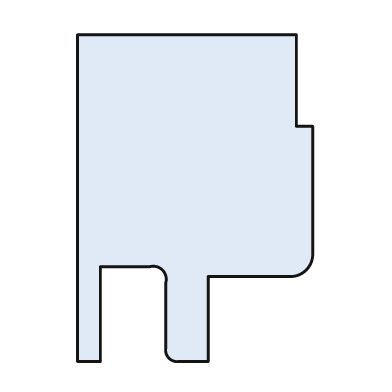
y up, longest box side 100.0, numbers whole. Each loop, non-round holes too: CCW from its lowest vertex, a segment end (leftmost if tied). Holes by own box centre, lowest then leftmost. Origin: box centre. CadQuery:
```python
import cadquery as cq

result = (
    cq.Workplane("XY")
    .moveTo(-36.0, -50.0)
    .lineTo(-29.0, -50.0)
    .lineTo(-29.0, -21.0)
    .lineTo(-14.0, -21.0)
    .threePointArc((-10.0, -22.0), (-9.0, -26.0))
    .lineTo(-9.0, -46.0)
    .threePointArc((-8.0, -49.0), (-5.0, -50.0))
    .lineTo(4.0, -50.0)
    .lineTo(4.0, -24.0)
    .lineTo(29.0, -24.0)
    .threePointArc((34.0, -22.0), (36.0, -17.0))
    .lineTo(36.0, 22.0)
    .lineTo(31.0, 22.0)
    .lineTo(31.0, 50.0)
    .lineTo(-36.0, 50.0)
    .close()
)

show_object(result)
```